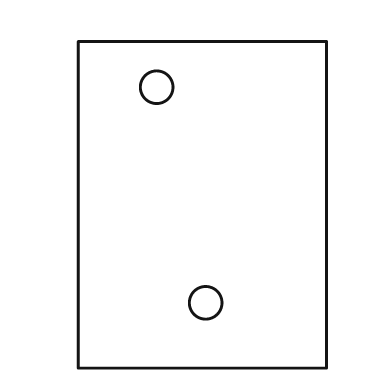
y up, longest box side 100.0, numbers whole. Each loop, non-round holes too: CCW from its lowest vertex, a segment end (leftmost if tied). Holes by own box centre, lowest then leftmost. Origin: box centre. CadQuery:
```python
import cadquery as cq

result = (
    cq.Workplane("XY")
    .moveTo(-38.0, -50.0)
    .lineTo(38.0, -50.0)
    .lineTo(38.0, 50.0)
    .lineTo(-38.0, 50.0)
    .close()
    .moveTo(1.0, -30.0)
    .circle(5.0)
    .moveTo(-14.0, 36.0)
    .circle(5.0)
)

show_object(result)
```